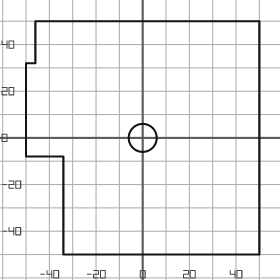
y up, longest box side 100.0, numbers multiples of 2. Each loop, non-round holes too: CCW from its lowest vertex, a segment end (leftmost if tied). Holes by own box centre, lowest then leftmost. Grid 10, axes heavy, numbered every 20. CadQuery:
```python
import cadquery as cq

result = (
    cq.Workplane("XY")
    .moveTo(-34.0, -50.0)
    .lineTo(50.0, -50.0)
    .lineTo(50.0, 50.0)
    .lineTo(-46.0, 50.0)
    .lineTo(-46.0, 32.0)
    .lineTo(-50.0, 32.0)
    .lineTo(-50.0, -8.0)
    .lineTo(-34.0, -8.0)
    .close()
    .moveTo(0.0, 0.0)
    .circle(6.0)
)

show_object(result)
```